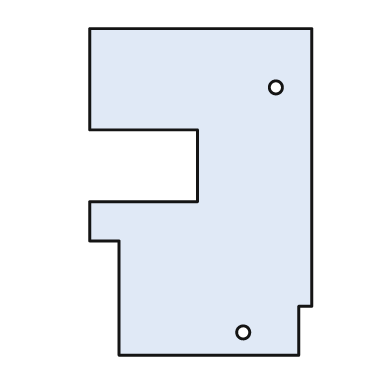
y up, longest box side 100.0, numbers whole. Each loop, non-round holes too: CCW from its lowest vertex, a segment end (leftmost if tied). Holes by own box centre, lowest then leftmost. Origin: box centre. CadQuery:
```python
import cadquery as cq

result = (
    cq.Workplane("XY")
    .moveTo(-25.0, -50.0)
    .lineTo(30.0, -50.0)
    .lineTo(30.0, -35.0)
    .lineTo(34.0, -35.0)
    .lineTo(34.0, 50.0)
    .lineTo(-34.0, 50.0)
    .lineTo(-34.0, 19.0)
    .lineTo(-1.0, 19.0)
    .lineTo(-1.0, -3.0)
    .lineTo(-34.0, -3.0)
    .lineTo(-34.0, -15.0)
    .lineTo(-25.0, -15.0)
    .close()
    .moveTo(13.0, -43.0)
    .circle(2.0)
    .moveTo(23.0, 32.0)
    .circle(2.0)
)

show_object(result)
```